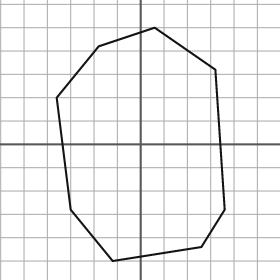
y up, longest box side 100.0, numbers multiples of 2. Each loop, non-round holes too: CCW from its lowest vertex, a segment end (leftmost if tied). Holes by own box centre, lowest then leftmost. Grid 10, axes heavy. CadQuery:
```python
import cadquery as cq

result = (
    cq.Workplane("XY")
    .moveTo(-12.0, -50.0)
    .lineTo(26.0, -44.0)
    .lineTo(36.0, -28.0)
    .lineTo(32.0, 32.0)
    .lineTo(6.0, 50.0)
    .lineTo(-18.0, 42.0)
    .lineTo(-36.0, 20.0)
    .lineTo(-30.0, -28.0)
    .close()
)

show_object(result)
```